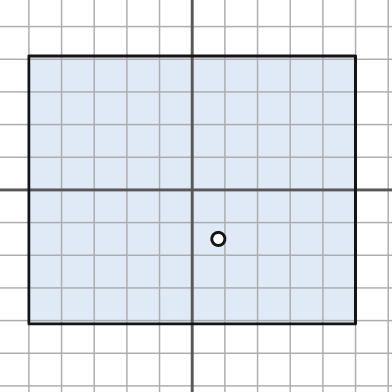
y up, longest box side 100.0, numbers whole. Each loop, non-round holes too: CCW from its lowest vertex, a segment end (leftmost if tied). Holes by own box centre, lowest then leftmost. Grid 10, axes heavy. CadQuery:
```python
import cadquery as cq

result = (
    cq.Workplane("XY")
    .moveTo(-50.0, -41.0)
    .lineTo(50.0, -41.0)
    .lineTo(50.0, 41.0)
    .lineTo(-50.0, 41.0)
    .close()
    .moveTo(8.0, -15.0)
    .circle(2.0)
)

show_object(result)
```